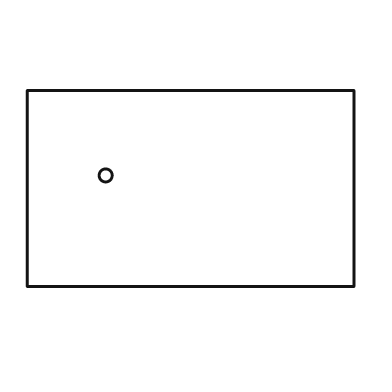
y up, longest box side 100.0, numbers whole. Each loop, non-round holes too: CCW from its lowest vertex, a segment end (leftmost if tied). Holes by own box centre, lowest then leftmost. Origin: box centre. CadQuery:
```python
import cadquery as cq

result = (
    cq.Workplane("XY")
    .moveTo(-50.0, -30.0)
    .lineTo(50.0, -30.0)
    .lineTo(50.0, 30.0)
    .lineTo(-50.0, 30.0)
    .close()
    .moveTo(-26.0, 4.0)
    .circle(2.0)
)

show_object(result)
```